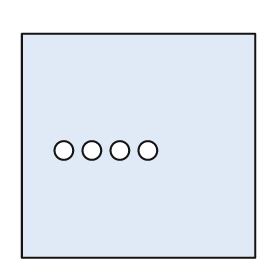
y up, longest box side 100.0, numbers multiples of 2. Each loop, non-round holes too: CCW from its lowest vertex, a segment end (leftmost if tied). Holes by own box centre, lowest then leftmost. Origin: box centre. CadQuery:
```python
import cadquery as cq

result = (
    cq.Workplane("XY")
    .moveTo(-50.0, -48.0)
    .lineTo(50.0, -48.0)
    .lineTo(50.0, 48.0)
    .lineTo(-50.0, 48.0)
    .close()
    .moveTo(-32.0, -2.0)
    .circle(4.0)
    .moveTo(-20.0, -2.0)
    .circle(4.0)
    .moveTo(-8.0, -2.0)
    .circle(4.0)
    .moveTo(4.0, -2.0)
    .circle(4.0)
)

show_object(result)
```